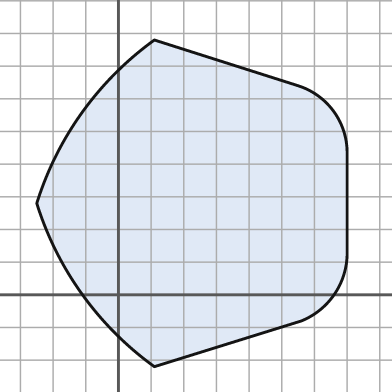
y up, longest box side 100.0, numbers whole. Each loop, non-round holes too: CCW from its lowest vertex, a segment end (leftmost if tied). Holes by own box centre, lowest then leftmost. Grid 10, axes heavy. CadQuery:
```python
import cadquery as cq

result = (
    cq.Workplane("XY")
    .moveTo(11.0, -22.0)
    .lineTo(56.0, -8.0)
    .threePointArc((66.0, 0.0), (70.0, 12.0))
    .lineTo(70.0, 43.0)
    .threePointArc((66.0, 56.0), (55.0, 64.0))
    .lineTo(11.0, 78.0)
    .threePointArc((-11.0, 56.0), (-25.0, 28.0))
    .threePointArc((-11.0, 0.0), (11.0, -22.0))
    .close()
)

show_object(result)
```